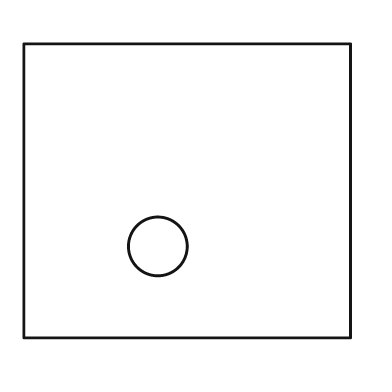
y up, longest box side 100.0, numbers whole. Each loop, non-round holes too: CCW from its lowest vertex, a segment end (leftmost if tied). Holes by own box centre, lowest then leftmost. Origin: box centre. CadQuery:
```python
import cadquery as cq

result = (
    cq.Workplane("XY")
    .moveTo(-50.0, -45.0)
    .lineTo(50.0, -45.0)
    .lineTo(50.0, 45.0)
    .lineTo(-50.0, 45.0)
    .close()
    .moveTo(-9.0, -17.0)
    .circle(9.0)
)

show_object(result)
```